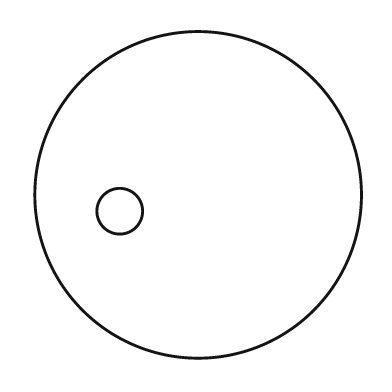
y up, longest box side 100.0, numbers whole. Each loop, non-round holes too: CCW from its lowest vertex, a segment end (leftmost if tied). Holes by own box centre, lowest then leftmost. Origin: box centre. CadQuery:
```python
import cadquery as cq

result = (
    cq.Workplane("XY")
    .moveTo(0.0, 0.0)
    .circle(50.0)
    .moveTo(-24.0, -5.0)
    .circle(7.0)
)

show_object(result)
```